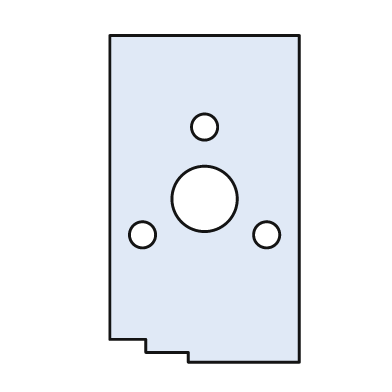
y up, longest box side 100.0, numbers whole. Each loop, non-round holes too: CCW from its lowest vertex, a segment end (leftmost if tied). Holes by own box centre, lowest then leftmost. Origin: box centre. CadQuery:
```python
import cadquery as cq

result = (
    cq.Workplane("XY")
    .moveTo(-5.0, -50.0)
    .lineTo(29.0, -50.0)
    .lineTo(29.0, 50.0)
    .lineTo(-29.0, 50.0)
    .lineTo(-29.0, -43.0)
    .lineTo(-18.0, -43.0)
    .lineTo(-18.0, -47.0)
    .lineTo(-5.0, -47.0)
    .close()
    .moveTo(-19.0, -11.0)
    .circle(4.0)
    .moveTo(19.0, -11.0)
    .circle(4.0)
    .moveTo(0.0, 0.0)
    .circle(10.0)
    .moveTo(0.0, 22.0)
    .circle(4.0)
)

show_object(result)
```